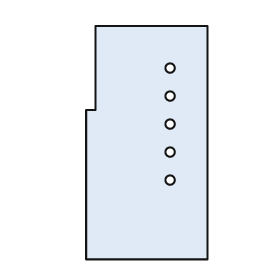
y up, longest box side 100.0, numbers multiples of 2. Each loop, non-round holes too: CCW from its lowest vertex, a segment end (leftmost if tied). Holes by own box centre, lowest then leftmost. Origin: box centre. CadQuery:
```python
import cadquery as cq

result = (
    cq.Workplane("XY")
    .moveTo(-26.0, -50.0)
    .lineTo(26.0, -50.0)
    .lineTo(26.0, 50.0)
    .lineTo(-22.0, 50.0)
    .lineTo(-22.0, 14.0)
    .lineTo(-26.0, 14.0)
    .close()
    .moveTo(10.0, -16.0)
    .circle(2.0)
    .moveTo(10.0, -4.0)
    .circle(2.0)
    .moveTo(10.0, 8.0)
    .circle(2.0)
    .moveTo(10.0, 20.0)
    .circle(2.0)
    .moveTo(10.0, 32.0)
    .circle(2.0)
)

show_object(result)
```